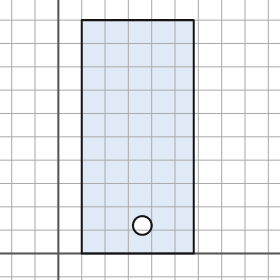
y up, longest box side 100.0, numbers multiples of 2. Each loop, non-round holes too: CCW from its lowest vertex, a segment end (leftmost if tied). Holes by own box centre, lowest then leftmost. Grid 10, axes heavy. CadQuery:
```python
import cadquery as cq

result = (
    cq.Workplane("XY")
    .moveTo(10.0, 0.0)
    .lineTo(58.0, 0.0)
    .lineTo(58.0, 100.0)
    .lineTo(10.0, 100.0)
    .close()
    .moveTo(36.0, 12.0)
    .circle(4.0)
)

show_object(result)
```